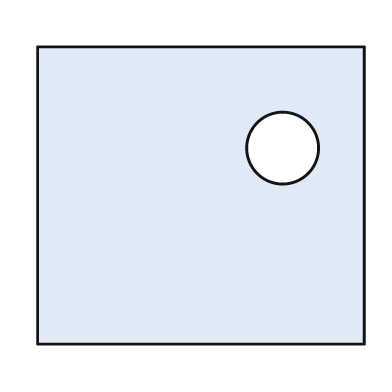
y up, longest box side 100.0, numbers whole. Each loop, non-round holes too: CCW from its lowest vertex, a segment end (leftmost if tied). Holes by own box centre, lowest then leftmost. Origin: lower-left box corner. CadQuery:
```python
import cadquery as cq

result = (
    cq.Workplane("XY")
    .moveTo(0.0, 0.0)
    .lineTo(100.0, 0.0)
    .lineTo(100.0, 91.0)
    .lineTo(0.0, 91.0)
    .close()
    .moveTo(75.0, 60.0)
    .circle(11.0)
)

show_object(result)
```